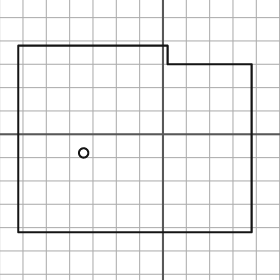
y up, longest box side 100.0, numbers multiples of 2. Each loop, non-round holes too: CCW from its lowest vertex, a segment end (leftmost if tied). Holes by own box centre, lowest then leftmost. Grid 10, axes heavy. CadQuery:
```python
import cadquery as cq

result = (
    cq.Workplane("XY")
    .moveTo(-62.0, -42.0)
    .lineTo(38.0, -42.0)
    .lineTo(38.0, 30.0)
    .lineTo(2.0, 30.0)
    .lineTo(2.0, 38.0)
    .lineTo(-62.0, 38.0)
    .close()
    .moveTo(-34.0, -8.0)
    .circle(2.0)
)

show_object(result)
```